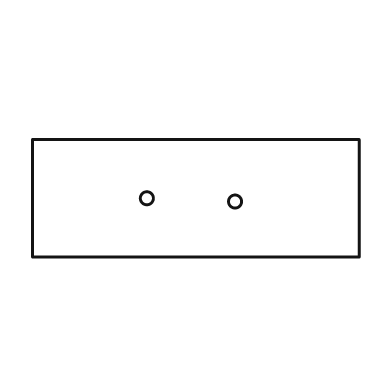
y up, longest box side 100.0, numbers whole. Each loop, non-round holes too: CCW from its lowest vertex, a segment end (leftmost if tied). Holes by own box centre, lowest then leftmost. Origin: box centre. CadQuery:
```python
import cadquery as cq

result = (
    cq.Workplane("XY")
    .moveTo(-50.0, -18.0)
    .lineTo(50.0, -18.0)
    .lineTo(50.0, 18.0)
    .lineTo(-50.0, 18.0)
    .close()
    .moveTo(12.0, -1.0)
    .circle(2.0)
    .moveTo(-15.0, 0.0)
    .circle(2.0)
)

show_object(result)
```